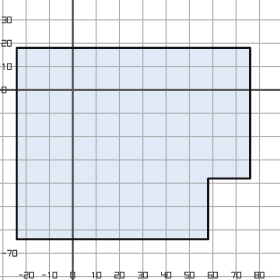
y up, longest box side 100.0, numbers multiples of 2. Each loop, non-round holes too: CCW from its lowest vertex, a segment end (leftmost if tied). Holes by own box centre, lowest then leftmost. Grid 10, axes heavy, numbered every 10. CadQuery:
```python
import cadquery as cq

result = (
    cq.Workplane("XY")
    .moveTo(-24.0, -64.0)
    .lineTo(58.0, -64.0)
    .lineTo(58.0, -38.0)
    .lineTo(76.0, -38.0)
    .lineTo(76.0, 18.0)
    .lineTo(-24.0, 18.0)
    .close()
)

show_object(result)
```